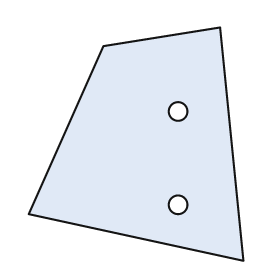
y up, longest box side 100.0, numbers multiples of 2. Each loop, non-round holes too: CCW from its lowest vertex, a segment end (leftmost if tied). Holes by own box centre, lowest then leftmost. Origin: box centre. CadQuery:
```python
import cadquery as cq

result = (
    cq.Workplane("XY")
    .moveTo(46.0, -50.0)
    .lineTo(36.0, 50.0)
    .lineTo(-14.0, 42.0)
    .lineTo(-46.0, -30.0)
    .close()
    .moveTo(18.0, -26.0)
    .circle(4.0)
    .moveTo(18.0, 14.0)
    .circle(4.0)
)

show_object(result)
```